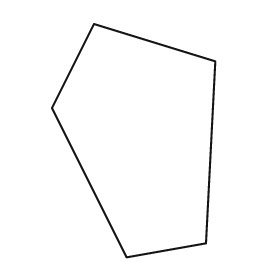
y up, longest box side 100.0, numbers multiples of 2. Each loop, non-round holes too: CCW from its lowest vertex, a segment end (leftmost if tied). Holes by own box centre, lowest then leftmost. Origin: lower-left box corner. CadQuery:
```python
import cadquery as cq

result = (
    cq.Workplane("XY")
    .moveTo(32.0, 0.0)
    .lineTo(66.0, 6.0)
    .lineTo(70.0, 84.0)
    .lineTo(18.0, 100.0)
    .lineTo(0.0, 64.0)
    .close()
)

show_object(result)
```